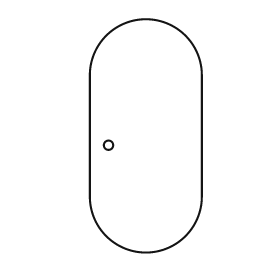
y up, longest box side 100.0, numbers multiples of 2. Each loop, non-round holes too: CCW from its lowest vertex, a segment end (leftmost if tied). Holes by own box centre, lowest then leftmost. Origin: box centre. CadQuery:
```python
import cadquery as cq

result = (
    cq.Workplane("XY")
    .moveTo(-24.0, -26.0)
    .threePointArc((0.0, -50.0), (24.0, -26.0))
    .lineTo(24.0, 26.0)
    .threePointArc((0.0, 50.0), (-24.0, 26.0))
    .close()
    .moveTo(-16.0, -4.0)
    .circle(2.0)
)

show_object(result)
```